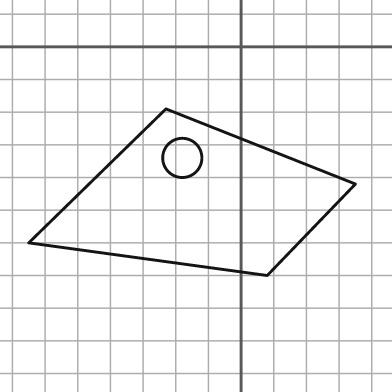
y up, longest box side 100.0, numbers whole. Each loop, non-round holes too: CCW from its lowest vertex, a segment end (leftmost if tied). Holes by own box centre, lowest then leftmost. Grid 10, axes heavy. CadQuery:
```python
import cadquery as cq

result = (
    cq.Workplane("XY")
    .moveTo(8.0, -70.0)
    .lineTo(35.0, -42.0)
    .lineTo(-23.0, -19.0)
    .lineTo(-65.0, -60.0)
    .close()
    .moveTo(-18.0, -34.0)
    .circle(6.0)
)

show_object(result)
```